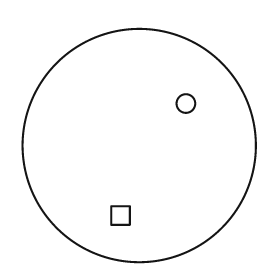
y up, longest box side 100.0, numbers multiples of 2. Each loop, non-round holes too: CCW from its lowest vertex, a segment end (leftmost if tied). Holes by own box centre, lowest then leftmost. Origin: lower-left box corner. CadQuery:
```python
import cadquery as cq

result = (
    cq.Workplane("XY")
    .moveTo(50.0, 50.0)
    .circle(50.0)
    .moveTo(38.0, 16.0)
    .lineTo(46.0, 16.0)
    .lineTo(46.0, 24.0)
    .lineTo(38.0, 24.0)
    .close()
    .moveTo(70.0, 68.0)
    .circle(4.0)
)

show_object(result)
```